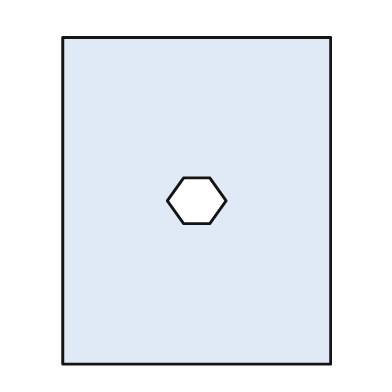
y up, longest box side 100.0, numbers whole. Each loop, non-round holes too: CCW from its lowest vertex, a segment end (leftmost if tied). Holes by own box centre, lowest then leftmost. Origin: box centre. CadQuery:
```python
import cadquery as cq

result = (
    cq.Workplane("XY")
    .moveTo(-41.0, -50.0)
    .lineTo(41.0, -50.0)
    .lineTo(41.0, 50.0)
    .lineTo(-41.0, 50.0)
    .close()
    .moveTo(-4.0, -7.0)
    .lineTo(4.0, -7.0)
    .lineTo(9.0, 0.0)
    .lineTo(4.0, 7.0)
    .lineTo(-4.0, 7.0)
    .lineTo(-9.0, 0.0)
    .close()
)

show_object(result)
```